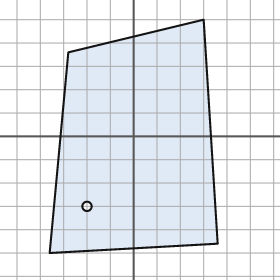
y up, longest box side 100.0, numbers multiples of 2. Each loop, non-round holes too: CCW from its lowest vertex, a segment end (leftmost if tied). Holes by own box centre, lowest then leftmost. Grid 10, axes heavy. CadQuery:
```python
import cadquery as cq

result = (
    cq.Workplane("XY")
    .moveTo(-36.0, -50.0)
    .lineTo(36.0, -46.0)
    .lineTo(30.0, 50.0)
    .lineTo(-28.0, 36.0)
    .close()
    .moveTo(-20.0, -30.0)
    .circle(2.0)
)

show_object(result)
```